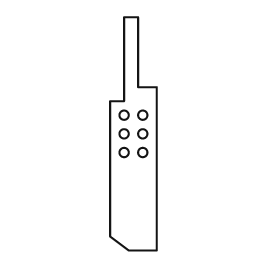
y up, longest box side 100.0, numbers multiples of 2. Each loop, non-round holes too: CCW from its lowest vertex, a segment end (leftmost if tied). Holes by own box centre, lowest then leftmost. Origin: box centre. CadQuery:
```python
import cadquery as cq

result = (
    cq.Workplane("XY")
    .moveTo(-2.0, -50.0)
    .lineTo(10.0, -50.0)
    .lineTo(10.0, 20.0)
    .lineTo(2.0, 20.0)
    .lineTo(2.0, 50.0)
    .lineTo(-4.0, 50.0)
    .lineTo(-4.0, 14.0)
    .lineTo(-10.0, 14.0)
    .lineTo(-10.0, -44.0)
    .close()
    .moveTo(-4.0, -8.0)
    .circle(2.0)
    .moveTo(4.0, -8.0)
    .circle(2.0)
    .moveTo(-4.0, 0.0)
    .circle(2.0)
    .moveTo(4.0, 0.0)
    .circle(2.0)
    .moveTo(-4.0, 8.0)
    .circle(2.0)
    .moveTo(4.0, 8.0)
    .circle(2.0)
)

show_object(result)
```